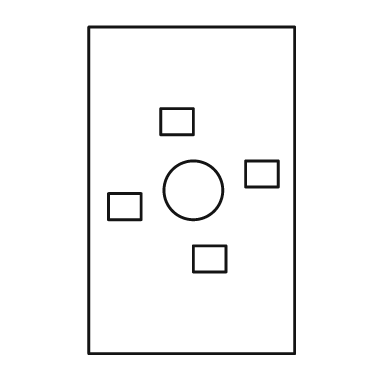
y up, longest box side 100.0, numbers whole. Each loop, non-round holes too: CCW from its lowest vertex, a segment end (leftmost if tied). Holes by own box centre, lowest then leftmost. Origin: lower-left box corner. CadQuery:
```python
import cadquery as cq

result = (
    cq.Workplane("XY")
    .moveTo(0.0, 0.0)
    .lineTo(63.0, 0.0)
    .lineTo(63.0, 100.0)
    .lineTo(0.0, 100.0)
    .close()
    .moveTo(32.0, 25.0)
    .lineTo(42.0, 25.0)
    .lineTo(42.0, 33.0)
    .lineTo(32.0, 33.0)
    .close()
    .moveTo(6.0, 41.0)
    .lineTo(16.0, 41.0)
    .lineTo(16.0, 49.0)
    .lineTo(6.0, 49.0)
    .close()
    .moveTo(32.0, 50.0)
    .circle(9.0)
    .moveTo(48.0, 51.0)
    .lineTo(58.0, 51.0)
    .lineTo(58.0, 59.0)
    .lineTo(48.0, 59.0)
    .close()
    .moveTo(22.0, 67.0)
    .lineTo(32.0, 67.0)
    .lineTo(32.0, 75.0)
    .lineTo(22.0, 75.0)
    .close()
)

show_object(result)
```